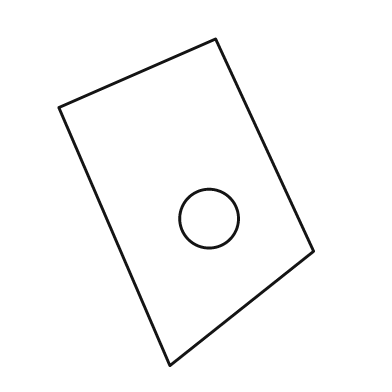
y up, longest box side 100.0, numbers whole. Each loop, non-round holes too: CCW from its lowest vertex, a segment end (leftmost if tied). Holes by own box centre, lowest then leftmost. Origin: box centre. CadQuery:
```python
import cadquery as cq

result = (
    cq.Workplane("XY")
    .moveTo(-5.0, -50.0)
    .lineTo(39.0, -15.0)
    .lineTo(9.0, 50.0)
    .lineTo(-39.0, 29.0)
    .close()
    .moveTo(7.0, -5.0)
    .circle(9.0)
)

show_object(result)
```